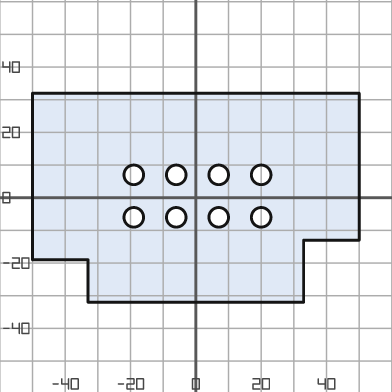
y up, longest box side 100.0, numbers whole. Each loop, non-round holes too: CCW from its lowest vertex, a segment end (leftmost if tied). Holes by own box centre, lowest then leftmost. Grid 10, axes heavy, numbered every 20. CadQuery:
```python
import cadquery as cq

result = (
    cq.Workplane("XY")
    .moveTo(-33.0, -32.0)
    .lineTo(33.0, -32.0)
    .lineTo(33.0, -13.0)
    .lineTo(50.0, -13.0)
    .lineTo(50.0, 32.0)
    .lineTo(-50.0, 32.0)
    .lineTo(-50.0, -19.0)
    .lineTo(-33.0, -19.0)
    .close()
    .moveTo(-19.0, -6.0)
    .circle(3.0)
    .moveTo(-6.0, -6.0)
    .circle(3.0)
    .moveTo(7.0, -6.0)
    .circle(3.0)
    .moveTo(20.0, -6.0)
    .circle(3.0)
    .moveTo(-19.0, 7.0)
    .circle(3.0)
    .moveTo(-6.0, 7.0)
    .circle(3.0)
    .moveTo(7.0, 7.0)
    .circle(3.0)
    .moveTo(20.0, 7.0)
    .circle(3.0)
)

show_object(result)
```